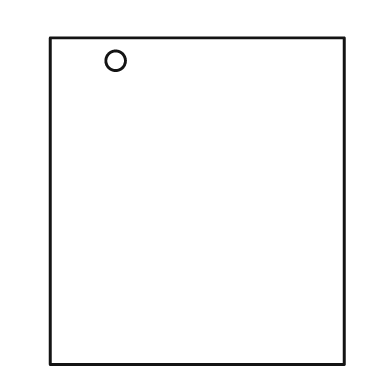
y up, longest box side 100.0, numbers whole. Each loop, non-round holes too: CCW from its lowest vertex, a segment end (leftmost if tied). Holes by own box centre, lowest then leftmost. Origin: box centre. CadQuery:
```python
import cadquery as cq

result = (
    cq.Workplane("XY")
    .moveTo(-45.0, -50.0)
    .lineTo(45.0, -50.0)
    .lineTo(45.0, 50.0)
    .lineTo(-45.0, 50.0)
    .close()
    .moveTo(-25.0, 43.0)
    .circle(3.0)
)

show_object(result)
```